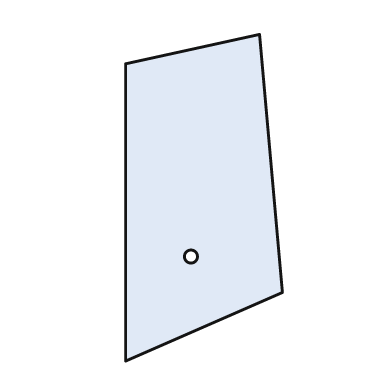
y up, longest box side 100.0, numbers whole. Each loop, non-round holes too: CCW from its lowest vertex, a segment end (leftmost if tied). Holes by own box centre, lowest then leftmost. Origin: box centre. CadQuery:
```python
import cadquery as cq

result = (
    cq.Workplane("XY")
    .moveTo(-24.0, -50.0)
    .lineTo(24.0, -29.0)
    .lineTo(17.0, 50.0)
    .lineTo(-24.0, 41.0)
    .close()
    .moveTo(-4.0, -18.0)
    .circle(2.0)
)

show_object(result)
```